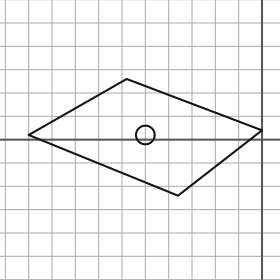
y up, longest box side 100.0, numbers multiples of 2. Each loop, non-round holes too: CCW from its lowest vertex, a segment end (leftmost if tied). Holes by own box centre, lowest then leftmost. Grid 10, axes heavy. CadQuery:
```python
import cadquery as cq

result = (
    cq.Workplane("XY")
    .moveTo(-36.0, -24.0)
    .lineTo(0.0, 4.0)
    .lineTo(-58.0, 26.0)
    .lineTo(-100.0, 2.0)
    .close()
    .moveTo(-50.0, 2.0)
    .circle(4.0)
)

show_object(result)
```